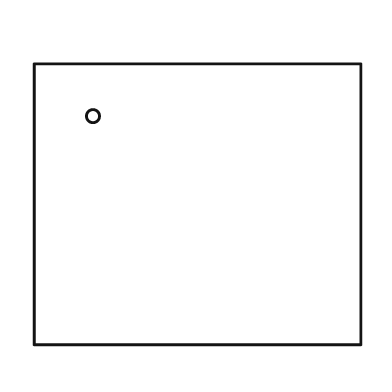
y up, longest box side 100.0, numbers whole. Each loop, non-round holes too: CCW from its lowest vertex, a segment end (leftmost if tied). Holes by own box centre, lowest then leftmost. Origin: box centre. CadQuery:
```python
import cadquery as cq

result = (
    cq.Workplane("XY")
    .moveTo(-50.0, -43.0)
    .lineTo(50.0, -43.0)
    .lineTo(50.0, 43.0)
    .lineTo(-50.0, 43.0)
    .close()
    .moveTo(-32.0, 27.0)
    .circle(2.0)
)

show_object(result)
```